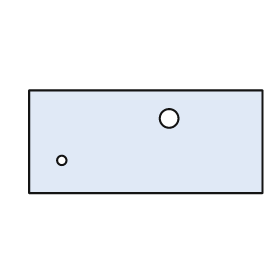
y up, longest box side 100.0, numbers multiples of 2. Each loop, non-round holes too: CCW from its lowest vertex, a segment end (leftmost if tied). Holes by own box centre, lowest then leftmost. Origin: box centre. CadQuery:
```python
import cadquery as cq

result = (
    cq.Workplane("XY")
    .moveTo(-50.0, -22.0)
    .lineTo(50.0, -22.0)
    .lineTo(50.0, 22.0)
    .lineTo(-50.0, 22.0)
    .close()
    .moveTo(-36.0, -8.0)
    .circle(2.0)
    .moveTo(10.0, 10.0)
    .circle(4.0)
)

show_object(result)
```